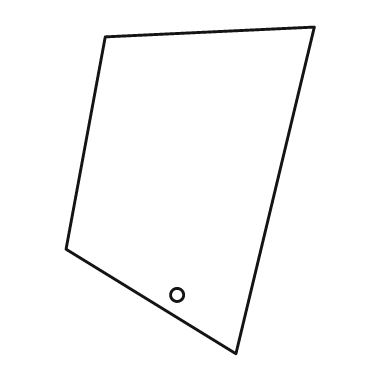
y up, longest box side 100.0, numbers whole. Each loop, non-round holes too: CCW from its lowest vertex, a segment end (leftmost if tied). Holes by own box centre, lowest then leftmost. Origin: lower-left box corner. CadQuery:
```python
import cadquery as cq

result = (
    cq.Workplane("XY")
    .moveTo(52.0, 0.0)
    .lineTo(76.0, 100.0)
    .lineTo(12.0, 97.0)
    .lineTo(0.0, 32.0)
    .close()
    .moveTo(34.0, 18.0)
    .circle(2.0)
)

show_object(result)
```